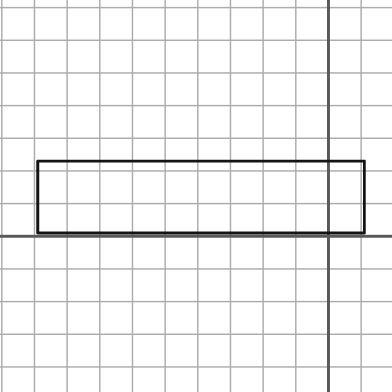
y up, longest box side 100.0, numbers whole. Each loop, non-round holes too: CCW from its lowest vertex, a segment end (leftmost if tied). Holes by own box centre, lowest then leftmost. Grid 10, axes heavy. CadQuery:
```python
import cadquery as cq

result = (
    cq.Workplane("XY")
    .moveTo(-89.0, 1.0)
    .lineTo(11.0, 1.0)
    .lineTo(11.0, 23.0)
    .lineTo(-89.0, 23.0)
    .close()
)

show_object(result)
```